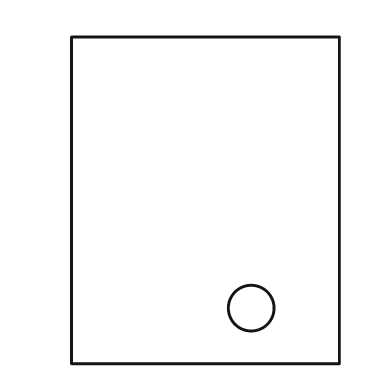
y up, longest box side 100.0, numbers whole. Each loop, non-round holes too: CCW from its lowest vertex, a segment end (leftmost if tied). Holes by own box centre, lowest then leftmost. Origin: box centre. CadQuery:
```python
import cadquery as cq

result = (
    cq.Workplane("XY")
    .moveTo(-41.0, -50.0)
    .lineTo(41.0, -50.0)
    .lineTo(41.0, 50.0)
    .lineTo(-41.0, 50.0)
    .close()
    .moveTo(14.0, -33.0)
    .circle(7.0)
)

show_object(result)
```